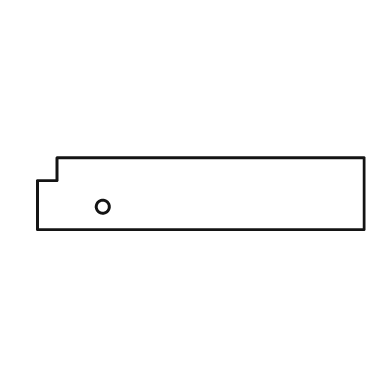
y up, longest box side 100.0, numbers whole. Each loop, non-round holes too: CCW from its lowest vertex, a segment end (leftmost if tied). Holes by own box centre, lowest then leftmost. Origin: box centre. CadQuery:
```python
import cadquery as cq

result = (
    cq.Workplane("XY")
    .moveTo(-50.0, -11.0)
    .lineTo(50.0, -11.0)
    .lineTo(50.0, 11.0)
    .lineTo(-44.0, 11.0)
    .lineTo(-44.0, 4.0)
    .lineTo(-50.0, 4.0)
    .close()
    .moveTo(-30.0, -4.0)
    .circle(2.0)
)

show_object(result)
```